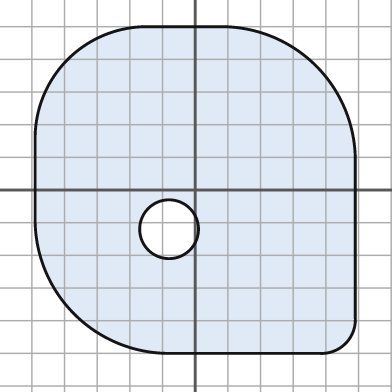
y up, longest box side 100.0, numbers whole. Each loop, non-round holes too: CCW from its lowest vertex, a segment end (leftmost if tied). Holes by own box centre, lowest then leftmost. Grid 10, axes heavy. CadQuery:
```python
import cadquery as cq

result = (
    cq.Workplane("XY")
    .moveTo(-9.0, -50.0)
    .lineTo(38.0, -50.0)
    .threePointArc((46.0, -47.0), (49.0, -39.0))
    .lineTo(49.0, 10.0)
    .threePointArc((37.0, 38.0), (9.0, 50.0))
    .lineTo(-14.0, 50.0)
    .threePointArc((-39.0, 40.0), (-49.0, 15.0))
    .lineTo(-49.0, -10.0)
    .threePointArc((-37.0, -38.0), (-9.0, -50.0))
    .close()
    .moveTo(-8.0, -12.0)
    .circle(9.0)
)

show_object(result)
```